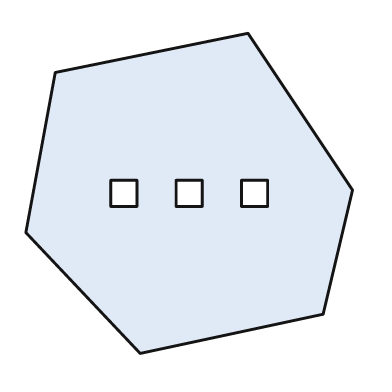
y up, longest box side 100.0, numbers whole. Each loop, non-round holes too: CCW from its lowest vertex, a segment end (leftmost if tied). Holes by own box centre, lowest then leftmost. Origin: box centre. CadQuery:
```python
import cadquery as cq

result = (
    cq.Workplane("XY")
    .moveTo(-15.0, -49.0)
    .lineTo(41.0, -37.0)
    .lineTo(50.0, 1.0)
    .lineTo(18.0, 49.0)
    .lineTo(-41.0, 37.0)
    .lineTo(-50.0, -12.0)
    .close()
    .moveTo(-24.0, -4.0)
    .lineTo(-16.0, -4.0)
    .lineTo(-16.0, 4.0)
    .lineTo(-24.0, 4.0)
    .close()
    .moveTo(-4.0, -4.0)
    .lineTo(4.0, -4.0)
    .lineTo(4.0, 4.0)
    .lineTo(-4.0, 4.0)
    .close()
    .moveTo(16.0, -4.0)
    .lineTo(24.0, -4.0)
    .lineTo(24.0, 4.0)
    .lineTo(16.0, 4.0)
    .close()
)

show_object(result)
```